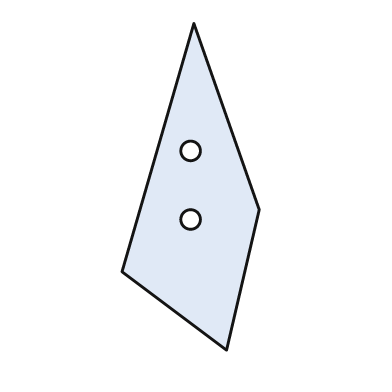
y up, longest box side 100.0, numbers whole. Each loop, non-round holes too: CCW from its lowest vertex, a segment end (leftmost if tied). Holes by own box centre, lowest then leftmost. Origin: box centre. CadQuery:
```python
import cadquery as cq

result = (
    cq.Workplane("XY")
    .moveTo(11.0, -50.0)
    .lineTo(21.0, -7.0)
    .lineTo(1.0, 50.0)
    .lineTo(-21.0, -26.0)
    .close()
    .moveTo(0.0, -10.0)
    .circle(3.0)
    .moveTo(0.0, 11.0)
    .circle(3.0)
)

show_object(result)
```